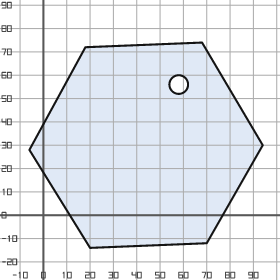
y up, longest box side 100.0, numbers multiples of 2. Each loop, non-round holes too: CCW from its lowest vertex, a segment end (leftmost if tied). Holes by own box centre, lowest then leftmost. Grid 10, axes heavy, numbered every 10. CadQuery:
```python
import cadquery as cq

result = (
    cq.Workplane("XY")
    .moveTo(20.0, -14.0)
    .lineTo(70.0, -12.0)
    .lineTo(94.0, 30.0)
    .lineTo(68.0, 74.0)
    .lineTo(18.0, 72.0)
    .lineTo(-6.0, 28.0)
    .close()
    .moveTo(58.0, 56.0)
    .circle(4.0)
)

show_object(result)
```